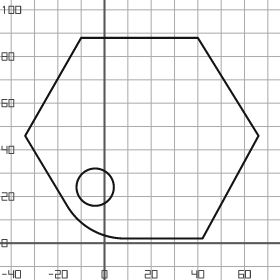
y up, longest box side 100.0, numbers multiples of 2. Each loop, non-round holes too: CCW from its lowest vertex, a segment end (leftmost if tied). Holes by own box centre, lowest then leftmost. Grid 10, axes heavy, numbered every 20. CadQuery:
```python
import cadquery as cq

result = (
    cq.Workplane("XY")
    .moveTo(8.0, 2.0)
    .lineTo(42.0, 2.0)
    .lineTo(66.0, 46.0)
    .lineTo(40.0, 88.0)
    .lineTo(-10.0, 88.0)
    .lineTo(-34.0, 46.0)
    .lineTo(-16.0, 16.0)
    .threePointArc((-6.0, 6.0), (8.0, 2.0))
    .close()
    .moveTo(-4.0, 24.0)
    .circle(8.0)
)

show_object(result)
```